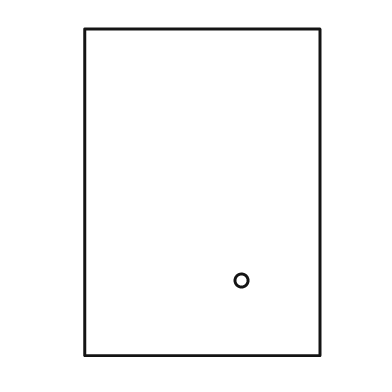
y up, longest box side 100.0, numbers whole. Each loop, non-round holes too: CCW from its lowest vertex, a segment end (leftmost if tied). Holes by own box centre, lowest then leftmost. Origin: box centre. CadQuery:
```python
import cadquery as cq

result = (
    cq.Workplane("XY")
    .moveTo(-36.0, -50.0)
    .lineTo(36.0, -50.0)
    .lineTo(36.0, 50.0)
    .lineTo(-36.0, 50.0)
    .close()
    .moveTo(12.0, -27.0)
    .circle(2.0)
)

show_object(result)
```